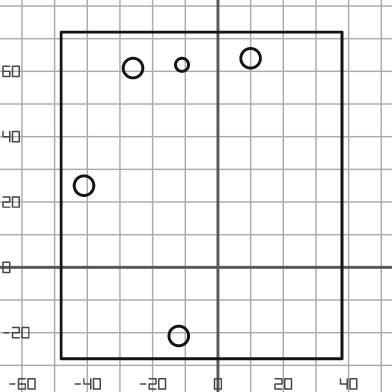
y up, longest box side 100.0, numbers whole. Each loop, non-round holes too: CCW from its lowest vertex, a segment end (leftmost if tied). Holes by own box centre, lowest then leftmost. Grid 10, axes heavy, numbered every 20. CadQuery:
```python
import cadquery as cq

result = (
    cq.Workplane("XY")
    .moveTo(-48.0, -28.0)
    .lineTo(38.0, -28.0)
    .lineTo(38.0, 72.0)
    .lineTo(-48.0, 72.0)
    .close()
    .moveTo(-12.0, -21.0)
    .circle(3.0)
    .moveTo(-41.0, 25.0)
    .circle(3.0)
    .moveTo(-26.0, 61.0)
    .circle(3.0)
    .moveTo(-11.0, 62.0)
    .circle(2.0)
    .moveTo(10.0, 64.0)
    .circle(3.0)
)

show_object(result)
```